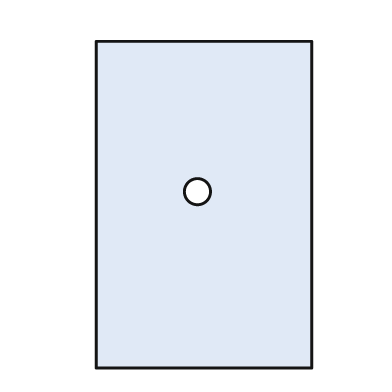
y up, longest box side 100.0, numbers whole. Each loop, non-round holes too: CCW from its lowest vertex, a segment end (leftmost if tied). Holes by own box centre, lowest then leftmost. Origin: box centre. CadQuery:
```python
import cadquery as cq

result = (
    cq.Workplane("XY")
    .moveTo(-33.0, -50.0)
    .lineTo(33.0, -50.0)
    .lineTo(33.0, 50.0)
    .lineTo(-33.0, 50.0)
    .close()
    .moveTo(-2.0, 4.0)
    .circle(4.0)
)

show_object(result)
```